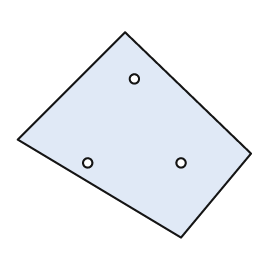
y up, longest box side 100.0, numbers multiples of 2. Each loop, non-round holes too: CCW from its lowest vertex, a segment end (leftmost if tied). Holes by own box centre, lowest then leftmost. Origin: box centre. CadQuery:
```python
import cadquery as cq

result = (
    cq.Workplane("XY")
    .moveTo(20.0, -44.0)
    .lineTo(50.0, -8.0)
    .lineTo(-4.0, 44.0)
    .lineTo(-50.0, -2.0)
    .close()
    .moveTo(-20.0, -12.0)
    .circle(2.0)
    .moveTo(20.0, -12.0)
    .circle(2.0)
    .moveTo(0.0, 24.0)
    .circle(2.0)
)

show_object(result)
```